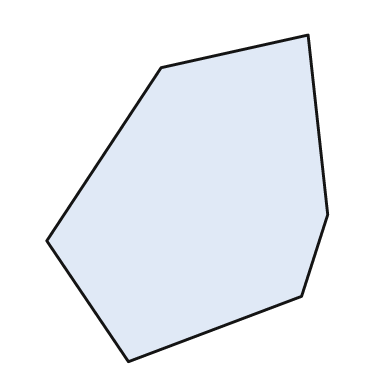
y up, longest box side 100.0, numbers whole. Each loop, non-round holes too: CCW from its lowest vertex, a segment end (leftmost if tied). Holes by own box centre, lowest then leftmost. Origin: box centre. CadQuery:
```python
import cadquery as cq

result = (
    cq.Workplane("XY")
    .moveTo(-18.0, -50.0)
    .lineTo(35.0, -30.0)
    .lineTo(43.0, -5.0)
    .lineTo(37.0, 50.0)
    .lineTo(-8.0, 40.0)
    .lineTo(-43.0, -13.0)
    .close()
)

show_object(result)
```